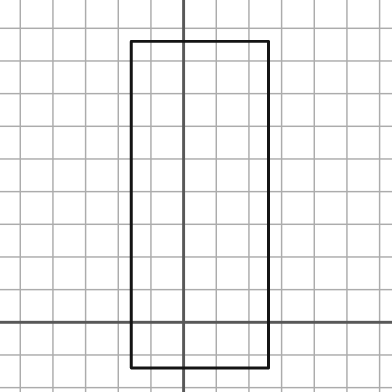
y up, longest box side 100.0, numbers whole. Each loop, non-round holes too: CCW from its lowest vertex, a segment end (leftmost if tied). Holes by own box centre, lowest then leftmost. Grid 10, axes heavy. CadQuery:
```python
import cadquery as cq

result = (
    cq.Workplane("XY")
    .moveTo(-16.0, -14.0)
    .lineTo(26.0, -14.0)
    .lineTo(26.0, 86.0)
    .lineTo(-16.0, 86.0)
    .close()
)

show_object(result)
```